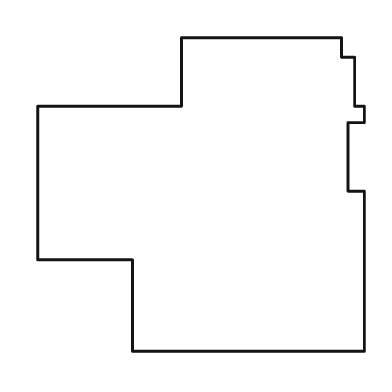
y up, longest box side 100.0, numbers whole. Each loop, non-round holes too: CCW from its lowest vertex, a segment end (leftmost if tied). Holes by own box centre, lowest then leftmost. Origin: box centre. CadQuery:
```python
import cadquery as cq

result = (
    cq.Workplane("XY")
    .moveTo(-21.0, -48.0)
    .lineTo(50.0, -48.0)
    .lineTo(50.0, 1.0)
    .lineTo(45.0, 1.0)
    .lineTo(45.0, 22.0)
    .lineTo(50.0, 22.0)
    .lineTo(50.0, 27.0)
    .lineTo(47.0, 27.0)
    .lineTo(47.0, 42.0)
    .lineTo(43.0, 42.0)
    .lineTo(43.0, 48.0)
    .lineTo(-6.0, 48.0)
    .lineTo(-6.0, 27.0)
    .lineTo(-50.0, 27.0)
    .lineTo(-50.0, -20.0)
    .lineTo(-21.0, -20.0)
    .close()
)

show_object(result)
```